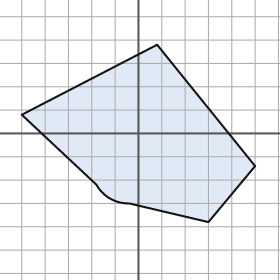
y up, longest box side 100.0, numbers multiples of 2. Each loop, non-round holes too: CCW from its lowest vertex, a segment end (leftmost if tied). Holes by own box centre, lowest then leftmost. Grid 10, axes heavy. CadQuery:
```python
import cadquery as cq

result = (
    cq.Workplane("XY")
    .moveTo(30.0, -38.0)
    .lineTo(50.0, -14.0)
    .lineTo(8.0, 38.0)
    .lineTo(-50.0, 8.0)
    .lineTo(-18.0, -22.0)
    .threePointArc((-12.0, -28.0), (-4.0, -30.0))
    .close()
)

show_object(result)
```